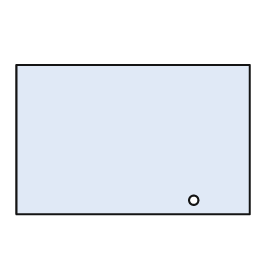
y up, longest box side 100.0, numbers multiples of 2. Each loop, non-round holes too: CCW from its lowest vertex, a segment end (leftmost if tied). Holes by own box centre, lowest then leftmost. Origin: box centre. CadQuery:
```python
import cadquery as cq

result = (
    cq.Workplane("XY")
    .moveTo(-50.0, -32.0)
    .lineTo(50.0, -32.0)
    .lineTo(50.0, 32.0)
    .lineTo(-50.0, 32.0)
    .close()
    .moveTo(26.0, -26.0)
    .circle(2.0)
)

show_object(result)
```